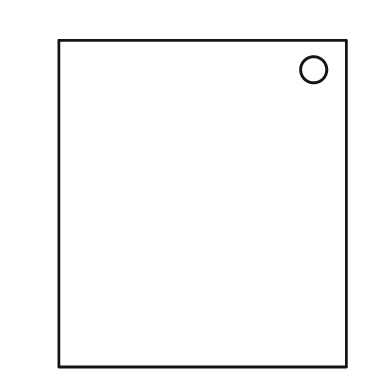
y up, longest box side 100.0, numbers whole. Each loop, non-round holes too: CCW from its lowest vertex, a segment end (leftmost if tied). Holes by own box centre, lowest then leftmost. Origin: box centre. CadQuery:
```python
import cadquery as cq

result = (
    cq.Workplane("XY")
    .moveTo(-44.0, -50.0)
    .lineTo(44.0, -50.0)
    .lineTo(44.0, 50.0)
    .lineTo(-44.0, 50.0)
    .close()
    .moveTo(34.0, 41.0)
    .circle(4.0)
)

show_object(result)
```